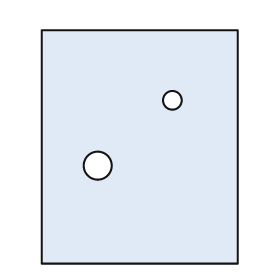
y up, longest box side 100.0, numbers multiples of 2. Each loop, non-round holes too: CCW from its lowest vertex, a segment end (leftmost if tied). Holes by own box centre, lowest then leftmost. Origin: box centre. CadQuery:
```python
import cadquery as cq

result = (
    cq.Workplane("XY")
    .moveTo(-42.0, -50.0)
    .lineTo(42.0, -50.0)
    .lineTo(42.0, 50.0)
    .lineTo(-42.0, 50.0)
    .close()
    .moveTo(-18.0, -8.0)
    .circle(6.0)
    .moveTo(14.0, 20.0)
    .circle(4.0)
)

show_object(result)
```